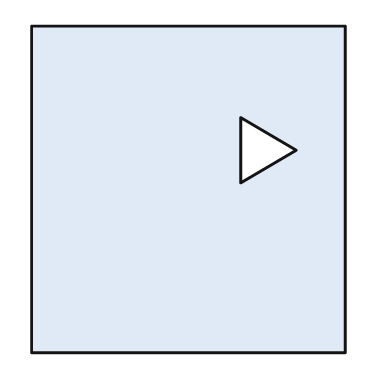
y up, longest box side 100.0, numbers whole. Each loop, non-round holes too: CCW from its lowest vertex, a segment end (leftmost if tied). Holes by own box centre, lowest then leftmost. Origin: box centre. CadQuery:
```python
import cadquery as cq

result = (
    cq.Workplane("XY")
    .moveTo(-48.0, -50.0)
    .lineTo(48.0, -50.0)
    .lineTo(48.0, 50.0)
    .lineTo(-48.0, 50.0)
    .close()
    .moveTo(16.0, 2.0)
    .lineTo(33.0, 12.0)
    .lineTo(16.0, 22.0)
    .close()
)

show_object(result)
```